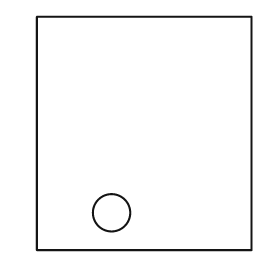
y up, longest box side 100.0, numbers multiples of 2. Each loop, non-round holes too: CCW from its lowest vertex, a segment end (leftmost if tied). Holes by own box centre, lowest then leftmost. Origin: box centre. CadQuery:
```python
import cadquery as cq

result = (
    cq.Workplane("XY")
    .moveTo(-46.0, -50.0)
    .lineTo(46.0, -50.0)
    .lineTo(46.0, 50.0)
    .lineTo(-46.0, 50.0)
    .close()
    .moveTo(-14.0, -34.0)
    .circle(8.0)
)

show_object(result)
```